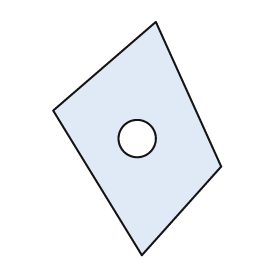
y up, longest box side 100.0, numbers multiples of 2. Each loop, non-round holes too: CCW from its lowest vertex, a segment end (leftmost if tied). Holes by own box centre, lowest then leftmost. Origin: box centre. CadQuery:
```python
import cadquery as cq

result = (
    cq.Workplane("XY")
    .moveTo(2.0, -50.0)
    .lineTo(36.0, -12.0)
    .lineTo(8.0, 50.0)
    .lineTo(-36.0, 12.0)
    .close()
    .moveTo(0.0, 0.0)
    .circle(8.0)
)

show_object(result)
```